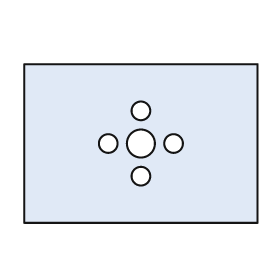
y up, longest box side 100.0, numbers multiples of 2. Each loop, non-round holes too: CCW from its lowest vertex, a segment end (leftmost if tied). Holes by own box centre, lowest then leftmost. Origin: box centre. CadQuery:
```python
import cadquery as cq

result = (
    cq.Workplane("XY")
    .moveTo(-50.0, -34.0)
    .lineTo(50.0, -34.0)
    .lineTo(50.0, 34.0)
    .lineTo(-50.0, 34.0)
    .close()
    .moveTo(0.0, -14.0)
    .circle(4.0)
    .moveTo(-14.0, 0.0)
    .circle(4.0)
    .moveTo(0.0, 0.0)
    .circle(6.0)
    .moveTo(14.0, 0.0)
    .circle(4.0)
    .moveTo(0.0, 14.0)
    .circle(4.0)
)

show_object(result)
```